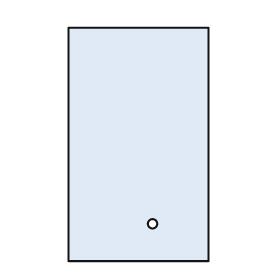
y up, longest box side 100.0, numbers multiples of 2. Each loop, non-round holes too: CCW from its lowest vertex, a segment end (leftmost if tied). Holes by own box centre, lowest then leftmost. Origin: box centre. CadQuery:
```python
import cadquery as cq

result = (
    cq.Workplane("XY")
    .moveTo(-30.0, -50.0)
    .lineTo(30.0, -50.0)
    .lineTo(30.0, 50.0)
    .lineTo(-30.0, 50.0)
    .close()
    .moveTo(6.0, -34.0)
    .circle(2.0)
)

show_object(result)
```